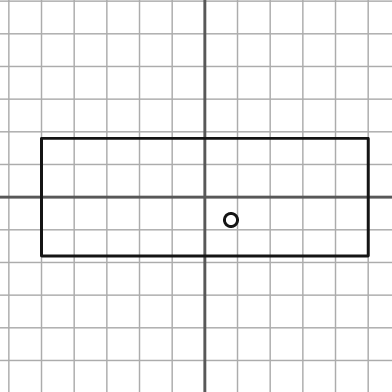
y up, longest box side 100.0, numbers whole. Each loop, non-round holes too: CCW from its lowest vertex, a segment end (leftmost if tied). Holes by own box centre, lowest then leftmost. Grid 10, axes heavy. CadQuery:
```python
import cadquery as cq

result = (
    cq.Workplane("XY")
    .moveTo(-50.0, -18.0)
    .lineTo(50.0, -18.0)
    .lineTo(50.0, 18.0)
    .lineTo(-50.0, 18.0)
    .close()
    .moveTo(8.0, -7.0)
    .circle(2.0)
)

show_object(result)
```